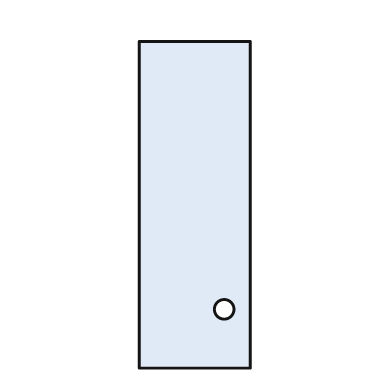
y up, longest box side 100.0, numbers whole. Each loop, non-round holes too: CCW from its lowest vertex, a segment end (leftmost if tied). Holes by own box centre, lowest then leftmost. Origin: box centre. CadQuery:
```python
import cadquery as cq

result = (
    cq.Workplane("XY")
    .moveTo(-17.0, -50.0)
    .lineTo(17.0, -50.0)
    .lineTo(17.0, 50.0)
    .lineTo(-17.0, 50.0)
    .close()
    .moveTo(9.0, -32.0)
    .circle(3.0)
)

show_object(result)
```